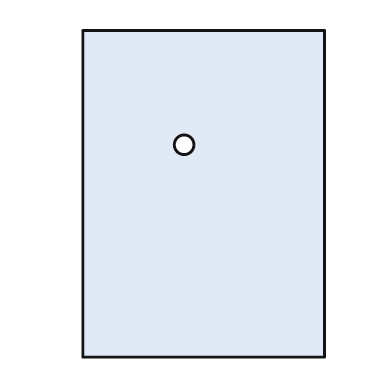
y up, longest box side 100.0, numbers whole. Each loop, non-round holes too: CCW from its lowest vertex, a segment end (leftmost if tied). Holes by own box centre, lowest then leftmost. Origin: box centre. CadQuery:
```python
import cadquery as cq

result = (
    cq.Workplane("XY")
    .moveTo(-37.0, -50.0)
    .lineTo(37.0, -50.0)
    .lineTo(37.0, 50.0)
    .lineTo(-37.0, 50.0)
    .close()
    .moveTo(-6.0, 15.0)
    .circle(3.0)
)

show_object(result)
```